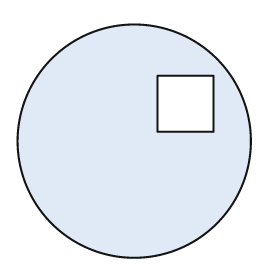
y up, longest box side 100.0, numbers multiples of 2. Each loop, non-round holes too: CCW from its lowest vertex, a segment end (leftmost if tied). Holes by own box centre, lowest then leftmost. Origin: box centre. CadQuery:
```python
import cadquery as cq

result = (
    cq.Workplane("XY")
    .moveTo(0.0, 0.0)
    .circle(50.0)
    .moveTo(10.0, 4.0)
    .lineTo(34.0, 4.0)
    .lineTo(34.0, 28.0)
    .lineTo(10.0, 28.0)
    .close()
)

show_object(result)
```